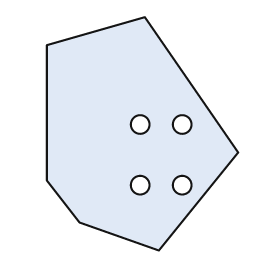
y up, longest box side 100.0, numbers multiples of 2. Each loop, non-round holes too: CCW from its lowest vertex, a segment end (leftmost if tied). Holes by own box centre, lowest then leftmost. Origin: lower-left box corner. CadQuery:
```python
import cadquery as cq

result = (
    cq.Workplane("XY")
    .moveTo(48.0, 0.0)
    .lineTo(82.0, 42.0)
    .lineTo(42.0, 100.0)
    .lineTo(0.0, 88.0)
    .lineTo(0.0, 30.0)
    .lineTo(14.0, 12.0)
    .close()
    .moveTo(40.0, 28.0)
    .circle(4.0)
    .moveTo(58.0, 28.0)
    .circle(4.0)
    .moveTo(40.0, 54.0)
    .circle(4.0)
    .moveTo(58.0, 54.0)
    .circle(4.0)
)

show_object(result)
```